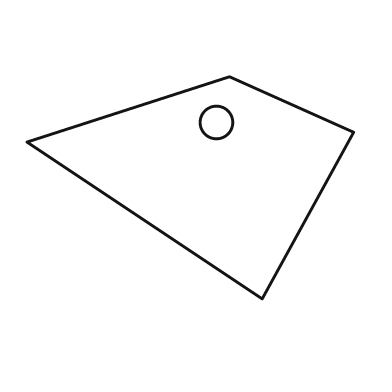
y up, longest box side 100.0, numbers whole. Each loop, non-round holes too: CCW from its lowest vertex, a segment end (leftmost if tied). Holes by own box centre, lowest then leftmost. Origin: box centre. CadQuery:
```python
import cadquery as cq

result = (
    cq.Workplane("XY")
    .moveTo(22.0, -34.0)
    .lineTo(50.0, 17.0)
    .lineTo(12.0, 34.0)
    .lineTo(-50.0, 14.0)
    .close()
    .moveTo(8.0, 20.0)
    .circle(5.0)
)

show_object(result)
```